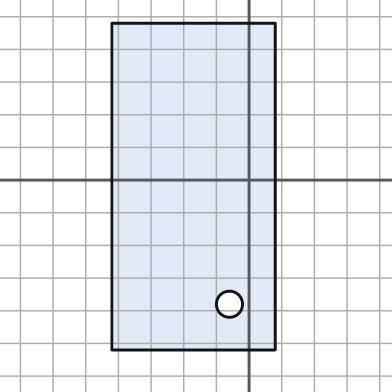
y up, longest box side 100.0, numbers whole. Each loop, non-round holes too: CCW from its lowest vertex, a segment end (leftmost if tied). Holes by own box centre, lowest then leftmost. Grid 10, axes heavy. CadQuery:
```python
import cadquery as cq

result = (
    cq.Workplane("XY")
    .moveTo(-42.0, -52.0)
    .lineTo(8.0, -52.0)
    .lineTo(8.0, 48.0)
    .lineTo(-42.0, 48.0)
    .close()
    .moveTo(-6.0, -38.0)
    .circle(4.0)
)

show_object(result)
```